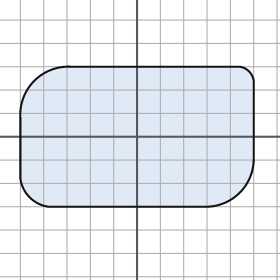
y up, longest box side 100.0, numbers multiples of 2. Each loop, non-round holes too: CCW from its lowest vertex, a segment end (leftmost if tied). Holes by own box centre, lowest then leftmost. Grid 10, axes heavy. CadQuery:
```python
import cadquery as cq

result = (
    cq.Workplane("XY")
    .moveTo(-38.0, -30.0)
    .lineTo(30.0, -30.0)
    .threePointArc((44.0, -24.0), (50.0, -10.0))
    .lineTo(50.0, 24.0)
    .threePointArc((48.0, 28.0), (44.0, 30.0))
    .lineTo(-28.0, 30.0)
    .threePointArc((-44.0, 24.0), (-50.0, 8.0))
    .lineTo(-50.0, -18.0)
    .threePointArc((-46.0, -26.0), (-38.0, -30.0))
    .close()
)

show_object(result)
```